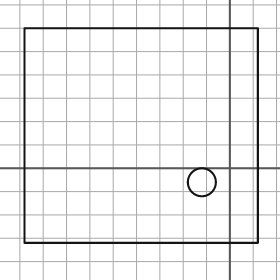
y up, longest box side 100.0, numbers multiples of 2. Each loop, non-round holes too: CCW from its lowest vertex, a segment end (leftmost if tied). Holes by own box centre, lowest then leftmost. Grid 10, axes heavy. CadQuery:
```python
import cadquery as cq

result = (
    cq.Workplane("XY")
    .moveTo(-88.0, -32.0)
    .lineTo(12.0, -32.0)
    .lineTo(12.0, 60.0)
    .lineTo(-88.0, 60.0)
    .close()
    .moveTo(-12.0, -6.0)
    .circle(6.0)
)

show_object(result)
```